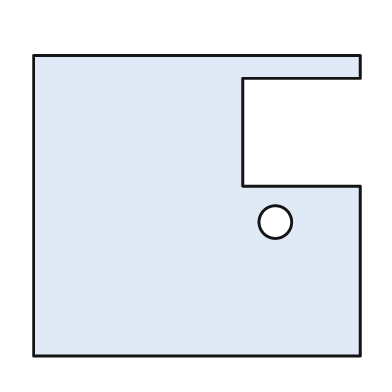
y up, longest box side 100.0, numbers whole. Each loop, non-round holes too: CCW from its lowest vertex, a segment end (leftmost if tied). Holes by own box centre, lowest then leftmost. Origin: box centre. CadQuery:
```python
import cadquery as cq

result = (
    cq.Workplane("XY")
    .moveTo(-50.0, -46.0)
    .lineTo(50.0, -46.0)
    .lineTo(50.0, 6.0)
    .lineTo(14.0, 6.0)
    .lineTo(14.0, 39.0)
    .lineTo(50.0, 39.0)
    .lineTo(50.0, 46.0)
    .lineTo(-50.0, 46.0)
    .close()
    .moveTo(24.0, -5.0)
    .circle(5.0)
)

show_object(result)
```